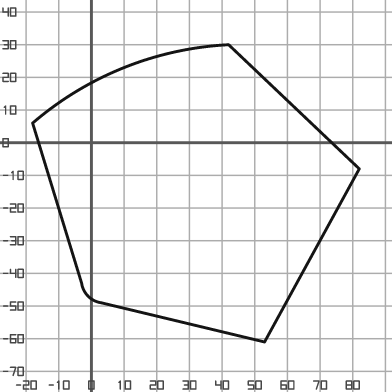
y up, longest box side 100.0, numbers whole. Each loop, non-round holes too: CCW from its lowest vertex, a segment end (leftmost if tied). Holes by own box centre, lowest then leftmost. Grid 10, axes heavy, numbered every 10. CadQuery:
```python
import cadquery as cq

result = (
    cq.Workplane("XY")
    .moveTo(53.0, -61.0)
    .lineTo(82.0, -8.0)
    .lineTo(42.0, 30.0)
    .threePointArc((10.0, 23.0), (-18.0, 6.0))
    .lineTo(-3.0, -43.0)
    .threePointArc((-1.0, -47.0), (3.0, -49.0))
    .close()
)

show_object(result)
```